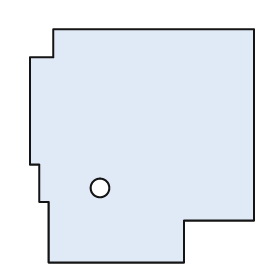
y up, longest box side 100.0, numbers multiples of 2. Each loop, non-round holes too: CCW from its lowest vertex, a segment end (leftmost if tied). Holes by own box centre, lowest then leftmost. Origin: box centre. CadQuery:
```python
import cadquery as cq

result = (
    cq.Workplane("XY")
    .moveTo(-40.0, -50.0)
    .lineTo(18.0, -50.0)
    .lineTo(18.0, -32.0)
    .lineTo(48.0, -32.0)
    .lineTo(48.0, 50.0)
    .lineTo(-38.0, 50.0)
    .lineTo(-38.0, 38.0)
    .lineTo(-48.0, 38.0)
    .lineTo(-48.0, -8.0)
    .lineTo(-44.0, -8.0)
    .lineTo(-44.0, -24.0)
    .lineTo(-40.0, -24.0)
    .close()
    .moveTo(-18.0, -18.0)
    .circle(4.0)
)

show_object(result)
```